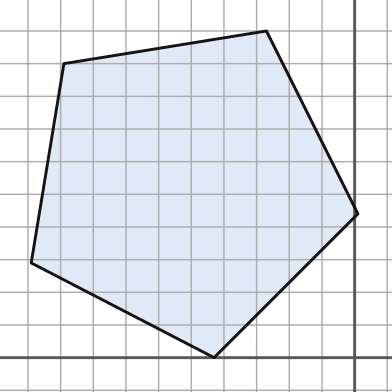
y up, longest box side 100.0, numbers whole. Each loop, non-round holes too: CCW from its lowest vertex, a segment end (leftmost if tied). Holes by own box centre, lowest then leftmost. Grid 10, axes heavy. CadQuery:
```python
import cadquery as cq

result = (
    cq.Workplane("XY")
    .moveTo(-43.0, 0.0)
    .lineTo(1.0, 44.0)
    .lineTo(-27.0, 100.0)
    .lineTo(-89.0, 90.0)
    .lineTo(-99.0, 29.0)
    .close()
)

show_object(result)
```